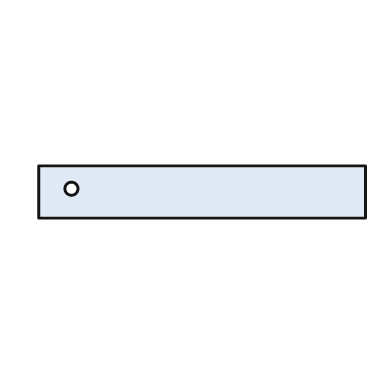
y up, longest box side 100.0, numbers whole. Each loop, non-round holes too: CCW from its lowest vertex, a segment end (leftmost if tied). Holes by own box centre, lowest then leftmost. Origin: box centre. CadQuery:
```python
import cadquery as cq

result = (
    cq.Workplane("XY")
    .moveTo(-50.0, -8.0)
    .lineTo(50.0, -8.0)
    .lineTo(50.0, 8.0)
    .lineTo(-50.0, 8.0)
    .close()
    .moveTo(-40.0, 1.0)
    .circle(2.0)
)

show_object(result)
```